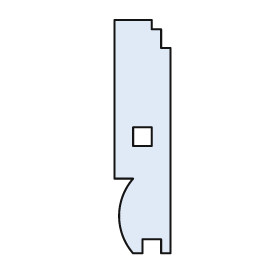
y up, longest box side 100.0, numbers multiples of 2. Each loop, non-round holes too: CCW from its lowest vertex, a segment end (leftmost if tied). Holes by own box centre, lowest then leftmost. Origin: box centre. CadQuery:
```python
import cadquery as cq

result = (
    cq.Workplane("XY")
    .moveTo(-4.0, -50.0)
    .lineTo(0.0, -50.0)
    .lineTo(0.0, -44.0)
    .lineTo(8.0, -44.0)
    .lineTo(8.0, -50.0)
    .lineTo(12.0, -50.0)
    .lineTo(12.0, 38.0)
    .lineTo(8.0, 38.0)
    .lineTo(8.0, 46.0)
    .lineTo(4.0, 46.0)
    .lineTo(4.0, 50.0)
    .lineTo(-12.0, 50.0)
    .lineTo(-12.0, -18.0)
    .lineTo(-4.0, -18.0)
    .threePointArc((-10.0, -34.0), (-4.0, -50.0))
    .close()
    .moveTo(-4.0, -4.0)
    .lineTo(4.0, -4.0)
    .lineTo(4.0, 4.0)
    .lineTo(-4.0, 4.0)
    .close()
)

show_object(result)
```